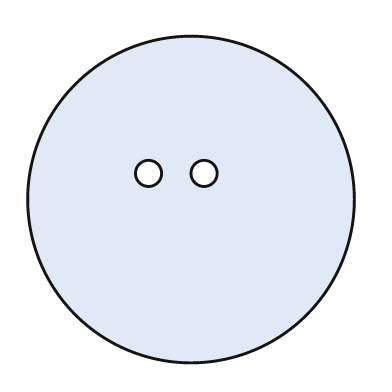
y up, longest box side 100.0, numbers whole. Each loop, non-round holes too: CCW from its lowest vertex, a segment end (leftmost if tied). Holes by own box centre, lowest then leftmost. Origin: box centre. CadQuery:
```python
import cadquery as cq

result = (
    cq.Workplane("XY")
    .moveTo(0.0, 0.0)
    .circle(50.0)
    .moveTo(-13.0, 8.0)
    .circle(4.0)
    .moveTo(4.0, 8.0)
    .circle(4.0)
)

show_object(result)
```